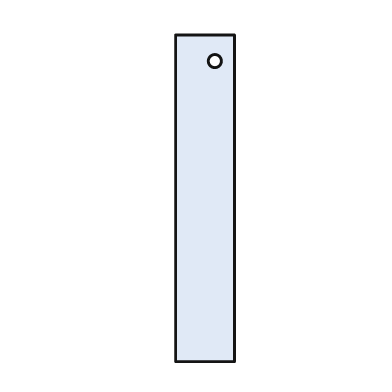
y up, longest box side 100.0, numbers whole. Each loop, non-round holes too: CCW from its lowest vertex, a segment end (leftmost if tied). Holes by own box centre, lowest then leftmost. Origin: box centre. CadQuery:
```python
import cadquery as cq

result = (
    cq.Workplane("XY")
    .moveTo(-9.0, -50.0)
    .lineTo(9.0, -50.0)
    .lineTo(9.0, 50.0)
    .lineTo(-9.0, 50.0)
    .close()
    .moveTo(3.0, 42.0)
    .circle(2.0)
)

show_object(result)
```